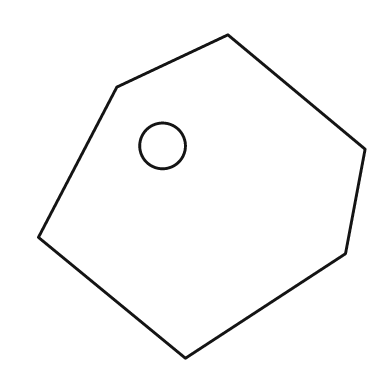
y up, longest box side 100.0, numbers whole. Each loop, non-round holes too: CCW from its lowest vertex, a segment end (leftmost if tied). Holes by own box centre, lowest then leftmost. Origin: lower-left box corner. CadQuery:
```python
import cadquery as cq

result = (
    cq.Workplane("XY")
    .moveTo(45.0, 0.0)
    .lineTo(94.0, 32.0)
    .lineTo(100.0, 64.0)
    .lineTo(58.0, 99.0)
    .lineTo(24.0, 83.0)
    .lineTo(0.0, 37.0)
    .close()
    .moveTo(38.0, 65.0)
    .circle(7.0)
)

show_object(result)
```